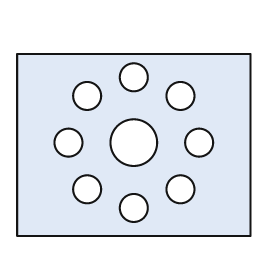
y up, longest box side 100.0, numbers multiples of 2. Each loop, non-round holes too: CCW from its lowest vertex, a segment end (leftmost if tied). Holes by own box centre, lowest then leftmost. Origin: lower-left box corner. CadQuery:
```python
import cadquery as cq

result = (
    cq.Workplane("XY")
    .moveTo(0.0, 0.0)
    .lineTo(100.0, 0.0)
    .lineTo(100.0, 78.0)
    .lineTo(0.0, 78.0)
    .close()
    .moveTo(50.0, 12.0)
    .circle(6.0)
    .moveTo(30.0, 20.0)
    .circle(6.0)
    .moveTo(70.0, 20.0)
    .circle(6.0)
    .moveTo(22.0, 40.0)
    .circle(6.0)
    .moveTo(50.0, 40.0)
    .circle(10.0)
    .moveTo(78.0, 40.0)
    .circle(6.0)
    .moveTo(30.0, 60.0)
    .circle(6.0)
    .moveTo(70.0, 60.0)
    .circle(6.0)
    .moveTo(50.0, 68.0)
    .circle(6.0)
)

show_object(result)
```